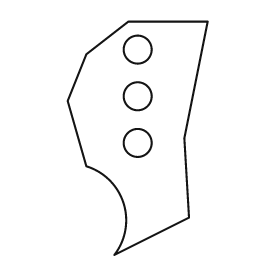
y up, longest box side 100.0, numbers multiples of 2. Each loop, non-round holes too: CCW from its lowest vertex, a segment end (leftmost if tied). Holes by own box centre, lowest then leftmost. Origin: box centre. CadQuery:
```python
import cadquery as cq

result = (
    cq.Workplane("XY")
    .moveTo(-10.0, -50.0)
    .lineTo(22.0, -34.0)
    .lineTo(20.0, 0.0)
    .lineTo(30.0, 50.0)
    .lineTo(-4.0, 50.0)
    .lineTo(-22.0, 36.0)
    .lineTo(-30.0, 16.0)
    .lineTo(-22.0, -12.0)
    .threePointArc((-6.0, -28.0), (-10.0, -50.0))
    .close()
    .moveTo(0.0, -2.0)
    .circle(6.0)
    .moveTo(0.0, 18.0)
    .circle(6.0)
    .moveTo(0.0, 38.0)
    .circle(6.0)
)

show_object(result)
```